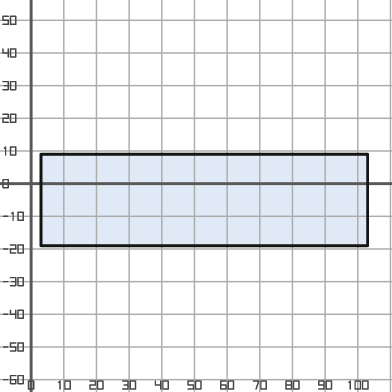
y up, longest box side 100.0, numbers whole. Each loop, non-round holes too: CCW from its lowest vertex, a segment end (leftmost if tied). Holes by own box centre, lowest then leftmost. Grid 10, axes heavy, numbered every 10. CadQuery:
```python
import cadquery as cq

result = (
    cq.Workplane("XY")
    .moveTo(3.0, -19.0)
    .lineTo(103.0, -19.0)
    .lineTo(103.0, 9.0)
    .lineTo(3.0, 9.0)
    .close()
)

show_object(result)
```